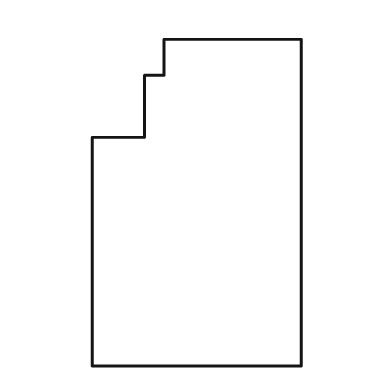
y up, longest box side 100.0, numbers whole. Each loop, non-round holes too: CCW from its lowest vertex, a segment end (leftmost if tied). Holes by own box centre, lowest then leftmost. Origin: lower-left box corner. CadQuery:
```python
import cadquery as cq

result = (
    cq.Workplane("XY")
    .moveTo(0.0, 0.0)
    .lineTo(64.0, 0.0)
    .lineTo(64.0, 100.0)
    .lineTo(22.0, 100.0)
    .lineTo(22.0, 89.0)
    .lineTo(16.0, 89.0)
    .lineTo(16.0, 70.0)
    .lineTo(0.0, 70.0)
    .close()
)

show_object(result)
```